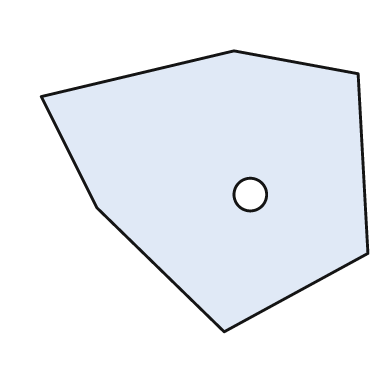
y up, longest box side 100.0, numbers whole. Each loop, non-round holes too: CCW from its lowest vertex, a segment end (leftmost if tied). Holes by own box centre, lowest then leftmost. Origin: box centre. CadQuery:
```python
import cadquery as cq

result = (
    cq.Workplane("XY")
    .moveTo(6.0, -43.0)
    .lineTo(50.0, -19.0)
    .lineTo(47.0, 36.0)
    .lineTo(9.0, 43.0)
    .lineTo(-50.0, 29.0)
    .lineTo(-33.0, -5.0)
    .close()
    .moveTo(14.0, -1.0)
    .circle(5.0)
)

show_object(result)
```